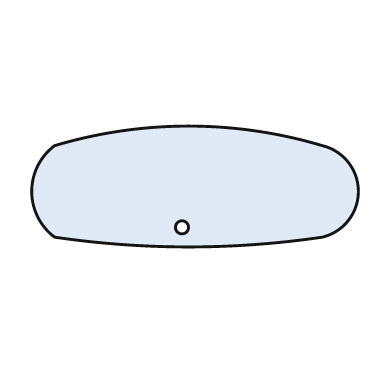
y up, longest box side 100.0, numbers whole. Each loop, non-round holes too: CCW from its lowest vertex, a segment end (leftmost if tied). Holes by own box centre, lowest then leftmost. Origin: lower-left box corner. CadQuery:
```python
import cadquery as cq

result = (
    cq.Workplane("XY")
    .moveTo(7.0, 3.0)
    .threePointArc((48.0, 0.0), (89.0, 3.0))
    .threePointArc((100.0, 17.0), (89.0, 31.0))
    .threePointArc((48.0, 37.0), (7.0, 31.0))
    .threePointArc((0.0, 17.0), (7.0, 3.0))
    .close()
    .moveTo(46.0, 6.0)
    .circle(2.0)
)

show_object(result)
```